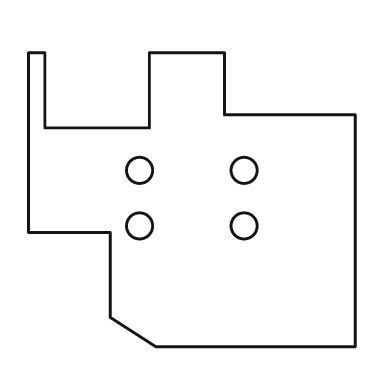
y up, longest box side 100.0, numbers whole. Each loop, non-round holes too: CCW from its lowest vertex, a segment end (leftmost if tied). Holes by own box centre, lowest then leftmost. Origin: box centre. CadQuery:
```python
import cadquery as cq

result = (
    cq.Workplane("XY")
    .moveTo(-11.0, -45.0)
    .lineTo(50.0, -45.0)
    .lineTo(50.0, 26.0)
    .lineTo(10.0, 26.0)
    .lineTo(10.0, 45.0)
    .lineTo(-13.0, 45.0)
    .lineTo(-13.0, 22.0)
    .lineTo(-45.0, 22.0)
    .lineTo(-45.0, 45.0)
    .lineTo(-50.0, 45.0)
    .lineTo(-50.0, -10.0)
    .lineTo(-25.0, -10.0)
    .lineTo(-25.0, -36.0)
    .close()
    .moveTo(-16.0, -8.0)
    .circle(4.0)
    .moveTo(16.0, -8.0)
    .circle(4.0)
    .moveTo(-16.0, 9.0)
    .circle(4.0)
    .moveTo(16.0, 9.0)
    .circle(4.0)
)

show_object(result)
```